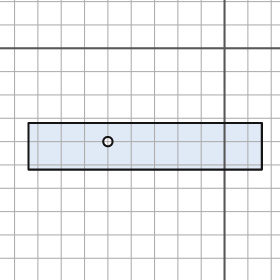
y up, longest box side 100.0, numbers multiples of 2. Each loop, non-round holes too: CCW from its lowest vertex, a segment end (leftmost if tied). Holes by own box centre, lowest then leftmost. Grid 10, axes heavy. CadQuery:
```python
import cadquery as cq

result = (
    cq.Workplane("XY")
    .moveTo(-84.0, -52.0)
    .lineTo(16.0, -52.0)
    .lineTo(16.0, -32.0)
    .lineTo(-84.0, -32.0)
    .close()
    .moveTo(-50.0, -40.0)
    .circle(2.0)
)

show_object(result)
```